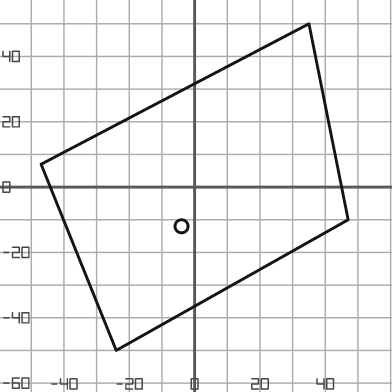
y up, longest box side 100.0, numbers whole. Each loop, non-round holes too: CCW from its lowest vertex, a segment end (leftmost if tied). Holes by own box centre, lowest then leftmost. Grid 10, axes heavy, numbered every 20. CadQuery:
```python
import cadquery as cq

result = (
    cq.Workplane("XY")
    .moveTo(-24.0, -50.0)
    .lineTo(47.0, -10.0)
    .lineTo(35.0, 50.0)
    .lineTo(-47.0, 7.0)
    .close()
    .moveTo(-4.0, -12.0)
    .circle(2.0)
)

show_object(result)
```